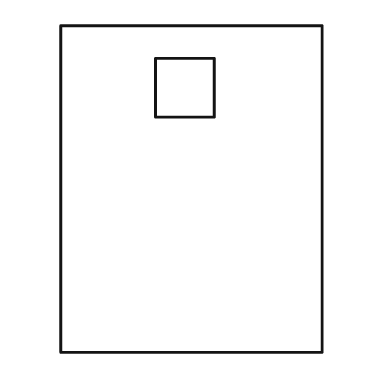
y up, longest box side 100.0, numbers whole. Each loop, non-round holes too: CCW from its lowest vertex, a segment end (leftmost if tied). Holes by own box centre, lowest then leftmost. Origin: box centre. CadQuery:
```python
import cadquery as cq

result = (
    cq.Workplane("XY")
    .moveTo(-40.0, -50.0)
    .lineTo(40.0, -50.0)
    .lineTo(40.0, 50.0)
    .lineTo(-40.0, 50.0)
    .close()
    .moveTo(-11.0, 22.0)
    .lineTo(7.0, 22.0)
    .lineTo(7.0, 40.0)
    .lineTo(-11.0, 40.0)
    .close()
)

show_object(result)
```